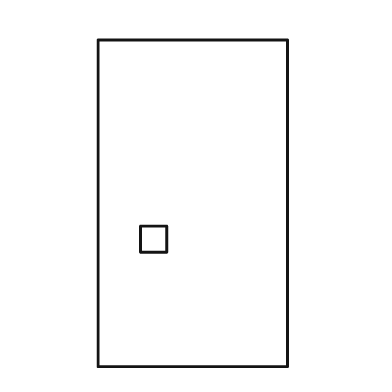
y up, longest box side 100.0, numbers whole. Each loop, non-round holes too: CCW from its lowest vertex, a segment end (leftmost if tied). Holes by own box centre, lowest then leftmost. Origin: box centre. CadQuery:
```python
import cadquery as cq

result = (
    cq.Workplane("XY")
    .moveTo(-29.0, -50.0)
    .lineTo(29.0, -50.0)
    .lineTo(29.0, 50.0)
    .lineTo(-29.0, 50.0)
    .close()
    .moveTo(-16.0, -15.0)
    .lineTo(-8.0, -15.0)
    .lineTo(-8.0, -7.0)
    .lineTo(-16.0, -7.0)
    .close()
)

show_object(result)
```